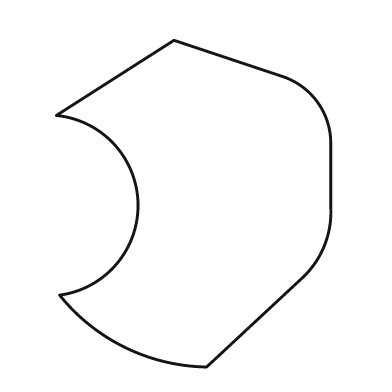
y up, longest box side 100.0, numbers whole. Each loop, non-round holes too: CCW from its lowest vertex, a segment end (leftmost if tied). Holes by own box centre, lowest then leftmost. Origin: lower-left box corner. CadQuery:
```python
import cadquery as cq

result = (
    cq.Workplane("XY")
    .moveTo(46.0, 0.0)
    .lineTo(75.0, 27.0)
    .threePointArc((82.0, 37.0), (84.0, 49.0))
    .lineTo(84.0, 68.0)
    .threePointArc((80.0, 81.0), (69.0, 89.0))
    .lineTo(36.0, 100.0)
    .lineTo(0.0, 77.0)
    .threePointArc((25.0, 50.0), (1.0, 22.0))
    .threePointArc((21.0, 6.0), (46.0, 0.0))
    .close()
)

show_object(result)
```